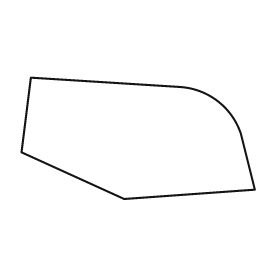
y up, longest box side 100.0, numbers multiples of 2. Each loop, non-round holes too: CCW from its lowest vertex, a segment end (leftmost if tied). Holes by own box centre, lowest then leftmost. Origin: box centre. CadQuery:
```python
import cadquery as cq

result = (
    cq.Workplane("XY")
    .moveTo(-6.0, -26.0)
    .lineTo(50.0, -22.0)
    .lineTo(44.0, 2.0)
    .threePointArc((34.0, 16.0), (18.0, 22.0))
    .lineTo(-46.0, 26.0)
    .lineTo(-50.0, -6.0)
    .close()
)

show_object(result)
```